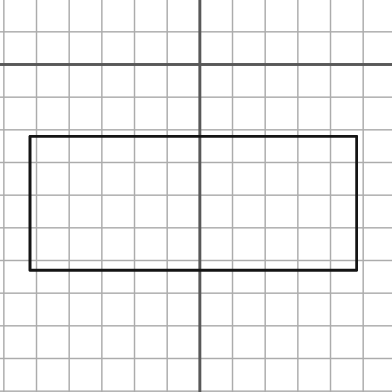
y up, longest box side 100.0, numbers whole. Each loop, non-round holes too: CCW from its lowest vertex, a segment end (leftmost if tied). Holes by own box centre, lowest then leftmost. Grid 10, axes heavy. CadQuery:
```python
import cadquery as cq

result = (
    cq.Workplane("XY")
    .moveTo(-52.0, -63.0)
    .lineTo(48.0, -63.0)
    .lineTo(48.0, -22.0)
    .lineTo(-52.0, -22.0)
    .close()
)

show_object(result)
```